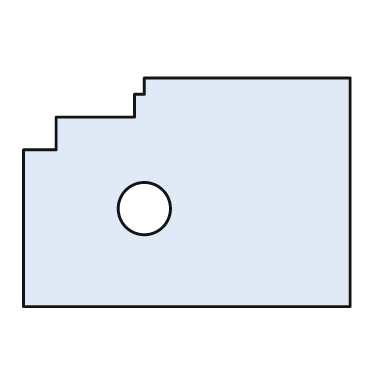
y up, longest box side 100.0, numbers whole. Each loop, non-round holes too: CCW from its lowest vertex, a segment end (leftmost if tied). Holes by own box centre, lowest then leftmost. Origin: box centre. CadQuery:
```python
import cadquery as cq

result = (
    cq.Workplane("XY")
    .moveTo(-50.0, -35.0)
    .lineTo(50.0, -35.0)
    .lineTo(50.0, 35.0)
    .lineTo(-13.0, 35.0)
    .lineTo(-13.0, 30.0)
    .lineTo(-16.0, 30.0)
    .lineTo(-16.0, 23.0)
    .lineTo(-40.0, 23.0)
    .lineTo(-40.0, 13.0)
    .lineTo(-50.0, 13.0)
    .close()
    .moveTo(-13.0, -5.0)
    .circle(8.0)
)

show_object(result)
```